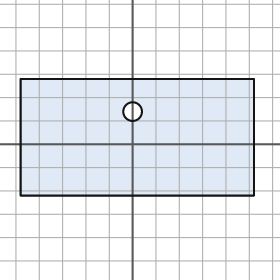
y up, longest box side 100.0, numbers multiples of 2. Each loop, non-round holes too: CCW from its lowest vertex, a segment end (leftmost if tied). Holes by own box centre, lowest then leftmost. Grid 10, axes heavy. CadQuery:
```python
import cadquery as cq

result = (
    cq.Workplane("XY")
    .moveTo(-48.0, -22.0)
    .lineTo(52.0, -22.0)
    .lineTo(52.0, 28.0)
    .lineTo(-48.0, 28.0)
    .close()
    .moveTo(0.0, 14.0)
    .circle(4.0)
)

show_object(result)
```